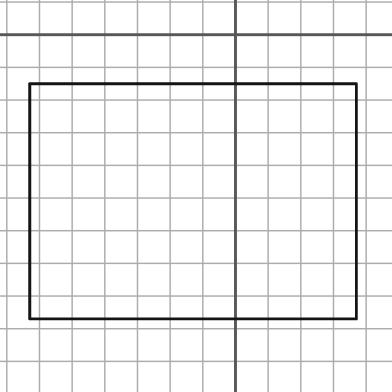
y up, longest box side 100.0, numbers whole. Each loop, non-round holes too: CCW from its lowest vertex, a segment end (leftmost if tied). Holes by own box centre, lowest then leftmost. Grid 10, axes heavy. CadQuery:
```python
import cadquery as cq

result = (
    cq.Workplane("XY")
    .moveTo(-63.0, -87.0)
    .lineTo(37.0, -87.0)
    .lineTo(37.0, -15.0)
    .lineTo(-63.0, -15.0)
    .close()
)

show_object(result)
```